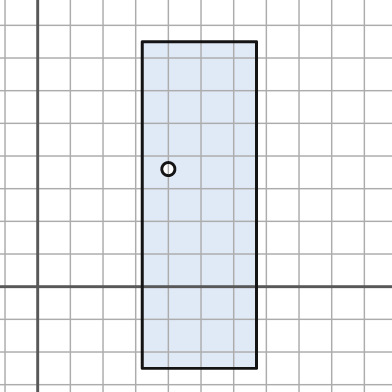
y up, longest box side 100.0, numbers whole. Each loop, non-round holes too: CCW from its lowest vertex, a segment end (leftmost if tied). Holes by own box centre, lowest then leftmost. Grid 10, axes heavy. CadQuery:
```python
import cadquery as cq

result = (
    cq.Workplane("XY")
    .moveTo(32.0, -25.0)
    .lineTo(67.0, -25.0)
    .lineTo(67.0, 75.0)
    .lineTo(32.0, 75.0)
    .close()
    .moveTo(40.0, 36.0)
    .circle(2.0)
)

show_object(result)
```